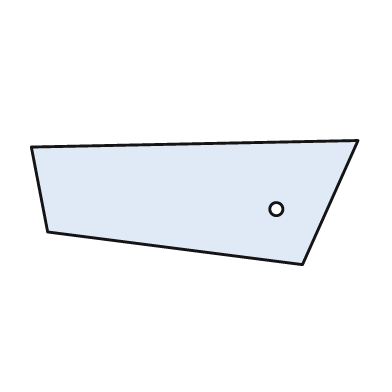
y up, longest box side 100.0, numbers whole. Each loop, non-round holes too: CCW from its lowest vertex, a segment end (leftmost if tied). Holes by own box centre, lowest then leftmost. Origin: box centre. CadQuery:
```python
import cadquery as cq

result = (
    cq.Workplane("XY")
    .moveTo(33.0, -19.0)
    .lineTo(50.0, 19.0)
    .lineTo(-50.0, 17.0)
    .lineTo(-45.0, -9.0)
    .close()
    .moveTo(25.0, -2.0)
    .circle(2.0)
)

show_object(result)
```